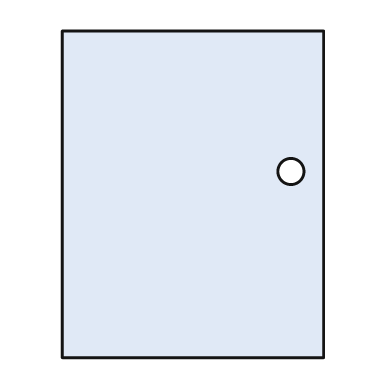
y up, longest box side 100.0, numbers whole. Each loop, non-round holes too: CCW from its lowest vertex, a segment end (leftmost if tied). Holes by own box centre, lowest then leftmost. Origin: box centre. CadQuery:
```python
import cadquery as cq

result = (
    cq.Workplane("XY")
    .moveTo(-40.0, -50.0)
    .lineTo(40.0, -50.0)
    .lineTo(40.0, 50.0)
    .lineTo(-40.0, 50.0)
    .close()
    .moveTo(30.0, 7.0)
    .circle(4.0)
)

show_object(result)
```